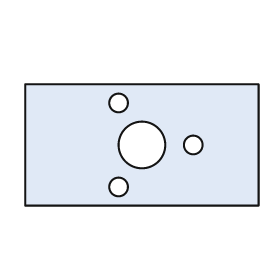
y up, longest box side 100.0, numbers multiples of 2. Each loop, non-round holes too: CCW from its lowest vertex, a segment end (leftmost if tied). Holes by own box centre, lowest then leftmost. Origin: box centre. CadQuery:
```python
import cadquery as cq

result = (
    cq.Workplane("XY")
    .moveTo(-50.0, -26.0)
    .lineTo(50.0, -26.0)
    .lineTo(50.0, 26.0)
    .lineTo(-50.0, 26.0)
    .close()
    .moveTo(-10.0, -18.0)
    .circle(4.0)
    .moveTo(0.0, 0.0)
    .circle(10.0)
    .moveTo(22.0, 0.0)
    .circle(4.0)
    .moveTo(-10.0, 18.0)
    .circle(4.0)
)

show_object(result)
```